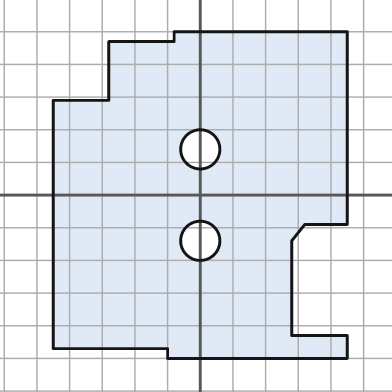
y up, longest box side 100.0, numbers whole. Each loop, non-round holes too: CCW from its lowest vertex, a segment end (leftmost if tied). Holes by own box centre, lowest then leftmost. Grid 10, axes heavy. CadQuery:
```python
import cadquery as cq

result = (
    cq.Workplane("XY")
    .moveTo(-10.0, -50.0)
    .lineTo(45.0, -50.0)
    .lineTo(45.0, -43.0)
    .lineTo(28.0, -43.0)
    .lineTo(28.0, -14.0)
    .lineTo(32.0, -9.0)
    .lineTo(45.0, -9.0)
    .lineTo(45.0, 50.0)
    .lineTo(-8.0, 50.0)
    .lineTo(-8.0, 47.0)
    .lineTo(-28.0, 47.0)
    .lineTo(-28.0, 29.0)
    .lineTo(-45.0, 29.0)
    .lineTo(-45.0, -47.0)
    .lineTo(-10.0, -47.0)
    .close()
    .moveTo(0.0, -14.0)
    .circle(6.0)
    .moveTo(0.0, 14.0)
    .circle(6.0)
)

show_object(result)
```